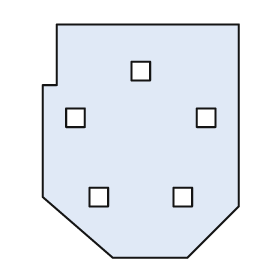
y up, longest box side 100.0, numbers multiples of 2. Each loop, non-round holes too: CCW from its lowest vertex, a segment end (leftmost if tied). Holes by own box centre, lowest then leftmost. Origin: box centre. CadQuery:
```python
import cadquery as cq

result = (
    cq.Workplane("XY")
    .moveTo(-12.0, -50.0)
    .lineTo(20.0, -50.0)
    .lineTo(42.0, -28.0)
    .lineTo(42.0, 50.0)
    .lineTo(-36.0, 50.0)
    .lineTo(-36.0, 24.0)
    .lineTo(-42.0, 24.0)
    .lineTo(-42.0, -24.0)
    .close()
    .moveTo(-22.0, -28.0)
    .lineTo(-14.0, -28.0)
    .lineTo(-14.0, -20.0)
    .lineTo(-22.0, -20.0)
    .close()
    .moveTo(14.0, -28.0)
    .lineTo(22.0, -28.0)
    .lineTo(22.0, -20.0)
    .lineTo(14.0, -20.0)
    .close()
    .moveTo(-32.0, 6.0)
    .lineTo(-24.0, 6.0)
    .lineTo(-24.0, 14.0)
    .lineTo(-32.0, 14.0)
    .close()
    .moveTo(24.0, 6.0)
    .lineTo(32.0, 6.0)
    .lineTo(32.0, 14.0)
    .lineTo(24.0, 14.0)
    .close()
    .moveTo(-4.0, 26.0)
    .lineTo(4.0, 26.0)
    .lineTo(4.0, 34.0)
    .lineTo(-4.0, 34.0)
    .close()
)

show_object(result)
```